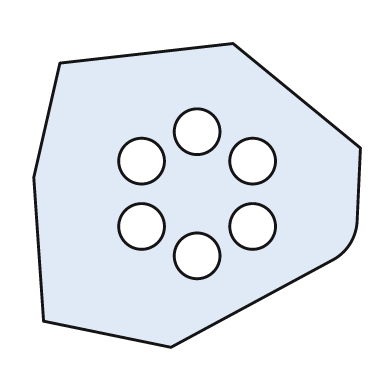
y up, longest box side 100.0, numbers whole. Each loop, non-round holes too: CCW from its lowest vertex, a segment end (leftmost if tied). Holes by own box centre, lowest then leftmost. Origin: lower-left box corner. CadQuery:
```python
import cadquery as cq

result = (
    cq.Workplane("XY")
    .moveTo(42.0, 0.0)
    .lineTo(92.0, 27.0)
    .threePointArc((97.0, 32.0), (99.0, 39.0))
    .lineTo(100.0, 61.0)
    .lineTo(61.0, 93.0)
    .lineTo(8.0, 87.0)
    .lineTo(0.0, 52.0)
    .lineTo(3.0, 8.0)
    .close()
    .moveTo(50.0, 28.0)
    .circle(7.0)
    .moveTo(33.0, 37.0)
    .circle(7.0)
    .moveTo(67.0, 37.0)
    .circle(7.0)
    .moveTo(33.0, 57.0)
    .circle(7.0)
    .moveTo(67.0, 57.0)
    .circle(7.0)
    .moveTo(50.0, 66.0)
    .circle(7.0)
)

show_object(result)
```